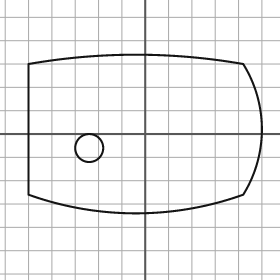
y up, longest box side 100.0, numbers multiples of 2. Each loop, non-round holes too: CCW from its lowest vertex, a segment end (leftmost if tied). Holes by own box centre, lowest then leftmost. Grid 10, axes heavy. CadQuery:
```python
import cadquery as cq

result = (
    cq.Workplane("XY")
    .moveTo(-50.0, -26.0)
    .threePointArc((-4.0, -34.0), (42.0, -26.0))
    .threePointArc((50.0, 2.0), (42.0, 30.0))
    .threePointArc((-4.0, 34.0), (-50.0, 30.0))
    .close()
    .moveTo(-24.0, -6.0)
    .circle(6.0)
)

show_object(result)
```